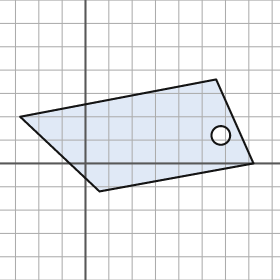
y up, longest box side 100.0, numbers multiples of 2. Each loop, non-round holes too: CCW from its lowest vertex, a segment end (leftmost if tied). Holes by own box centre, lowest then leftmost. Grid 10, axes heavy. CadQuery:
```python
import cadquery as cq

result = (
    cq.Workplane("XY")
    .moveTo(6.0, -12.0)
    .lineTo(72.0, 0.0)
    .lineTo(56.0, 36.0)
    .lineTo(-28.0, 20.0)
    .close()
    .moveTo(58.0, 12.0)
    .circle(4.0)
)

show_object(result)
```